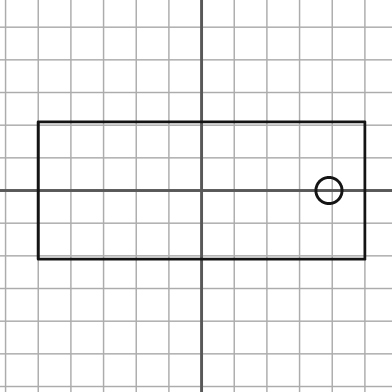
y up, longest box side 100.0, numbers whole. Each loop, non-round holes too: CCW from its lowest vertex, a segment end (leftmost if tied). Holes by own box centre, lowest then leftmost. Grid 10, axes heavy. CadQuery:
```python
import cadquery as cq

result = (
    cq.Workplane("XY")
    .moveTo(-50.0, -21.0)
    .lineTo(50.0, -21.0)
    .lineTo(50.0, 21.0)
    .lineTo(-50.0, 21.0)
    .close()
    .moveTo(39.0, 0.0)
    .circle(4.0)
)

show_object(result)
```